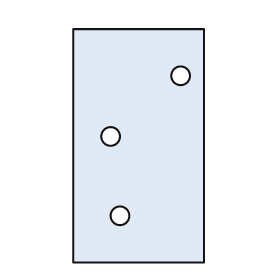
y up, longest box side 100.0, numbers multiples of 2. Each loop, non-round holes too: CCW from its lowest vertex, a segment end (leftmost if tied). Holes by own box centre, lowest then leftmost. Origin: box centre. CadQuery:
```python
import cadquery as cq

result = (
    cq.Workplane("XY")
    .moveTo(-28.0, -50.0)
    .lineTo(28.0, -50.0)
    .lineTo(28.0, 50.0)
    .lineTo(-28.0, 50.0)
    .close()
    .moveTo(-8.0, -30.0)
    .circle(4.0)
    .moveTo(-12.0, 4.0)
    .circle(4.0)
    .moveTo(18.0, 30.0)
    .circle(4.0)
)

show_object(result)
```